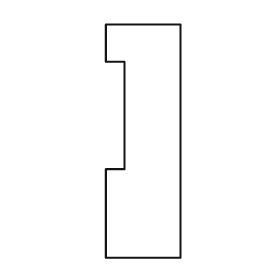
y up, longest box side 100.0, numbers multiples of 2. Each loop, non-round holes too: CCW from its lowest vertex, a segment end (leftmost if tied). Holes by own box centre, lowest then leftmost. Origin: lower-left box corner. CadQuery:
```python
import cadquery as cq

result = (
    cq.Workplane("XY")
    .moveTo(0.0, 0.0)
    .lineTo(32.0, 0.0)
    .lineTo(32.0, 100.0)
    .lineTo(0.0, 100.0)
    .lineTo(0.0, 84.0)
    .lineTo(8.0, 84.0)
    .lineTo(8.0, 38.0)
    .lineTo(0.0, 38.0)
    .close()
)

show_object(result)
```